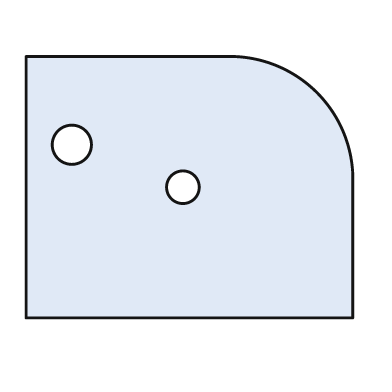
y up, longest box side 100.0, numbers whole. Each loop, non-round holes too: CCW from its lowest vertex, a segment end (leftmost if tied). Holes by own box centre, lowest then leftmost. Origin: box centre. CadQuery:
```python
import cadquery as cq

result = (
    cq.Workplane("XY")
    .moveTo(-50.0, -40.0)
    .lineTo(50.0, -40.0)
    .lineTo(50.0, 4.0)
    .threePointArc((39.0, 29.0), (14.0, 40.0))
    .lineTo(-50.0, 40.0)
    .close()
    .moveTo(-2.0, 0.0)
    .circle(5.0)
    .moveTo(-36.0, 13.0)
    .circle(6.0)
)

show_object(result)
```